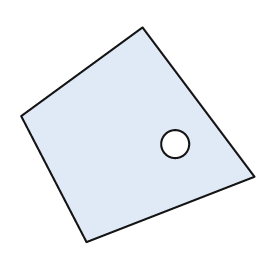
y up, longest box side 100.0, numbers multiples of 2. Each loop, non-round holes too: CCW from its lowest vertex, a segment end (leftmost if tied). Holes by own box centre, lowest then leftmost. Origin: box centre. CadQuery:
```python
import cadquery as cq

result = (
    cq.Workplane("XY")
    .moveTo(-22.0, -46.0)
    .lineTo(50.0, -18.0)
    .lineTo(2.0, 46.0)
    .lineTo(-50.0, 8.0)
    .close()
    .moveTo(16.0, -4.0)
    .circle(6.0)
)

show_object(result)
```